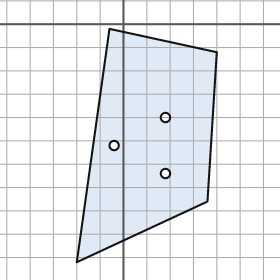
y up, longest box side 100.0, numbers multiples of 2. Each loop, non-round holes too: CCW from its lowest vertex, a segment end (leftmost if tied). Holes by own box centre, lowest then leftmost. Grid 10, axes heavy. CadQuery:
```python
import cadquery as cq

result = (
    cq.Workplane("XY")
    .moveTo(-20.0, -102.0)
    .lineTo(36.0, -76.0)
    .lineTo(40.0, -12.0)
    .lineTo(-6.0, -2.0)
    .close()
    .moveTo(18.0, -64.0)
    .circle(2.0)
    .moveTo(-4.0, -52.0)
    .circle(2.0)
    .moveTo(18.0, -40.0)
    .circle(2.0)
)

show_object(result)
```